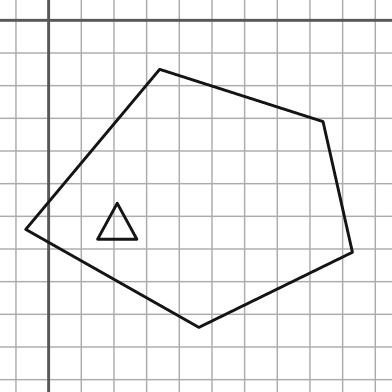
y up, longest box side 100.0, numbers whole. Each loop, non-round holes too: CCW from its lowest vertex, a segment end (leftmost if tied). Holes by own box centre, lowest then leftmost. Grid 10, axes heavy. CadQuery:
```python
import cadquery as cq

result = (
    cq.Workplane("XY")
    .moveTo(46.0, -94.0)
    .lineTo(93.0, -71.0)
    .lineTo(84.0, -31.0)
    .lineTo(34.0, -15.0)
    .lineTo(-7.0, -64.0)
    .close()
    .moveTo(15.0, -67.0)
    .lineTo(27.0, -67.0)
    .lineTo(21.0, -56.0)
    .close()
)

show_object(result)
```